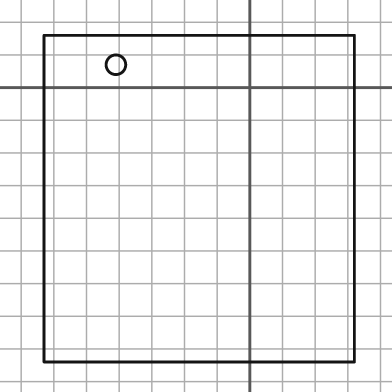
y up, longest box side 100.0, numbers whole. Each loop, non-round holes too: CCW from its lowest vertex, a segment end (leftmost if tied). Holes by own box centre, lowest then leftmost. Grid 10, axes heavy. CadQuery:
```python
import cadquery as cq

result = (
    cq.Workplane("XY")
    .moveTo(-63.0, -84.0)
    .lineTo(32.0, -84.0)
    .lineTo(32.0, 16.0)
    .lineTo(-63.0, 16.0)
    .close()
    .moveTo(-41.0, 7.0)
    .circle(3.0)
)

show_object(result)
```